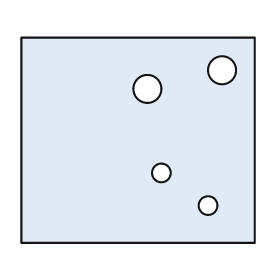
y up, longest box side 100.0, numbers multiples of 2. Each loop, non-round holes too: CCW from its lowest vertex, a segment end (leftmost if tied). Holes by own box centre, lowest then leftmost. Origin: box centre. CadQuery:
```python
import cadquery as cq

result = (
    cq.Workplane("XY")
    .moveTo(-50.0, -44.0)
    .lineTo(50.0, -44.0)
    .lineTo(50.0, 44.0)
    .lineTo(-50.0, 44.0)
    .close()
    .moveTo(30.0, -28.0)
    .circle(4.0)
    .moveTo(10.0, -14.0)
    .circle(4.0)
    .moveTo(4.0, 22.0)
    .circle(6.0)
    .moveTo(36.0, 30.0)
    .circle(6.0)
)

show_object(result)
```